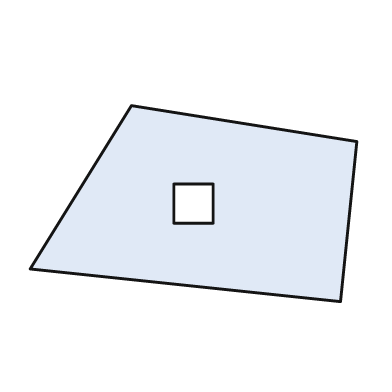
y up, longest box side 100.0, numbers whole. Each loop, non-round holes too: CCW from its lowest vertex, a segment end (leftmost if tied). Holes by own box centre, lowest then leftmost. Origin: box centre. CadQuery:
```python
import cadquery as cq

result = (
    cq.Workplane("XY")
    .moveTo(45.0, -30.0)
    .lineTo(50.0, 19.0)
    .lineTo(-19.0, 30.0)
    .lineTo(-50.0, -20.0)
    .close()
    .moveTo(-6.0, -6.0)
    .lineTo(6.0, -6.0)
    .lineTo(6.0, 6.0)
    .lineTo(-6.0, 6.0)
    .close()
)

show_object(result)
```